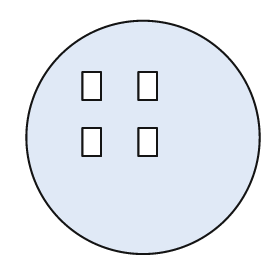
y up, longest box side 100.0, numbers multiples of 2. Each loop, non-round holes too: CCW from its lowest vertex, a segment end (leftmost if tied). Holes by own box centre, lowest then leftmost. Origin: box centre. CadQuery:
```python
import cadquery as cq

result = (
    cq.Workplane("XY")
    .moveTo(0.0, 0.0)
    .circle(50.0)
    .moveTo(-26.0, -8.0)
    .lineTo(-18.0, -8.0)
    .lineTo(-18.0, 4.0)
    .lineTo(-26.0, 4.0)
    .close()
    .moveTo(-2.0, -8.0)
    .lineTo(6.0, -8.0)
    .lineTo(6.0, 4.0)
    .lineTo(-2.0, 4.0)
    .close()
    .moveTo(-26.0, 16.0)
    .lineTo(-18.0, 16.0)
    .lineTo(-18.0, 28.0)
    .lineTo(-26.0, 28.0)
    .close()
    .moveTo(-2.0, 16.0)
    .lineTo(6.0, 16.0)
    .lineTo(6.0, 28.0)
    .lineTo(-2.0, 28.0)
    .close()
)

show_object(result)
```